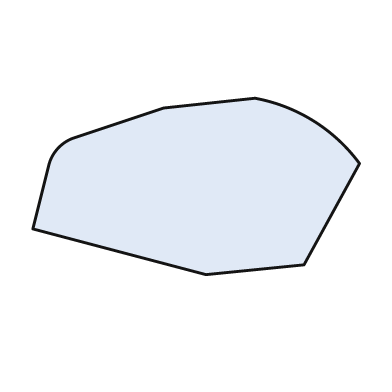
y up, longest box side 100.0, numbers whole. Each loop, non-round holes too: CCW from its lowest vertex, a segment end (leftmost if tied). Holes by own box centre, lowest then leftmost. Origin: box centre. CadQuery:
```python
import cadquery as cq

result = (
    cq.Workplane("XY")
    .moveTo(3.0, -27.0)
    .lineTo(33.0, -24.0)
    .lineTo(50.0, 7.0)
    .threePointArc((36.0, 20.0), (18.0, 27.0))
    .lineTo(-10.0, 24.0)
    .lineTo(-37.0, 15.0)
    .threePointArc((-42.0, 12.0), (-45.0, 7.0))
    .lineTo(-50.0, -13.0)
    .close()
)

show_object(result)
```